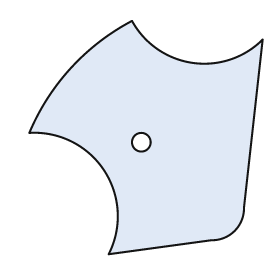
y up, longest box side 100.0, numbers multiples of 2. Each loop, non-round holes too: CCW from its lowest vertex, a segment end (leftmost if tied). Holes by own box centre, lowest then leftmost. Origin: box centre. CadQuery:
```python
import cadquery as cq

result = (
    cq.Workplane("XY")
    .moveTo(-16.0, -50.0)
    .lineTo(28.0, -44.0)
    .threePointArc((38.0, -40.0), (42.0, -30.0))
    .lineTo(50.0, 42.0)
    .threePointArc((20.0, 32.0), (-6.0, 50.0))
    .threePointArc((-32.0, 30.0), (-50.0, 2.0))
    .threePointArc((-18.0, -14.0), (-16.0, -50.0))
    .close()
    .moveTo(-2.0, -2.0)
    .circle(4.0)
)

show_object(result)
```